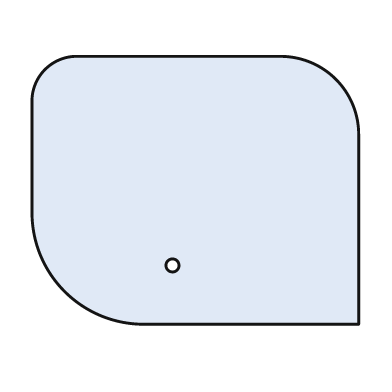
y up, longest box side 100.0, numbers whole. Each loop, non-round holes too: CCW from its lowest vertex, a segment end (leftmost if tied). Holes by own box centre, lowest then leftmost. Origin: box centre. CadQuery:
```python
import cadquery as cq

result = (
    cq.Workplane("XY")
    .moveTo(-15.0, -41.0)
    .lineTo(50.0, -41.0)
    .lineTo(50.0, 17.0)
    .threePointArc((43.0, 34.0), (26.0, 41.0))
    .lineTo(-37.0, 41.0)
    .threePointArc((-46.0, 37.0), (-50.0, 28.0))
    .lineTo(-50.0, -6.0)
    .threePointArc((-40.0, -31.0), (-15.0, -41.0))
    .close()
    .moveTo(-7.0, -23.0)
    .circle(2.0)
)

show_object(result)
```